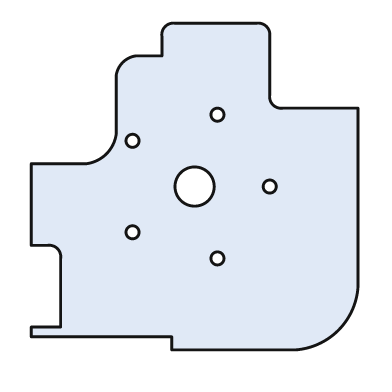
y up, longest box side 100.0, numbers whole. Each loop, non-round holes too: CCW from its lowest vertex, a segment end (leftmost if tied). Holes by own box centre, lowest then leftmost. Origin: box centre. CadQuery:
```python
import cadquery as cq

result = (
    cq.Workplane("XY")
    .moveTo(-7.0, -50.0)
    .lineTo(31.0, -50.0)
    .threePointArc((44.0, -44.0), (50.0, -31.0))
    .lineTo(50.0, 24.0)
    .lineTo(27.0, 24.0)
    .threePointArc((24.0, 25.0), (23.0, 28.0))
    .lineTo(23.0, 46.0)
    .threePointArc((22.0, 49.0), (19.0, 50.0))
    .lineTo(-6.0, 50.0)
    .threePointArc((-9.0, 49.0), (-10.0, 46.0))
    .lineTo(-10.0, 40.0)
    .lineTo(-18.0, 40.0)
    .threePointArc((-22.0, 38.0), (-24.0, 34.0))
    .lineTo(-24.0, 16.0)
    .threePointArc((-27.0, 10.0), (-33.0, 7.0))
    .lineTo(-50.0, 7.0)
    .lineTo(-50.0, -18.0)
    .lineTo(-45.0, -18.0)
    .threePointArc((-42.0, -19.0), (-41.0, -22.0))
    .lineTo(-41.0, -43.0)
    .lineTo(-50.0, -43.0)
    .lineTo(-50.0, -46.0)
    .lineTo(-7.0, -46.0)
    .close()
    .moveTo(7.0, -22.0)
    .circle(2.0)
    .moveTo(-19.0, -14.0)
    .circle(2.0)
    .moveTo(0.0, 0.0)
    .circle(6.0)
    .moveTo(23.0, 0.0)
    .circle(2.0)
    .moveTo(-19.0, 14.0)
    .circle(2.0)
    .moveTo(7.0, 22.0)
    .circle(2.0)
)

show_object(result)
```